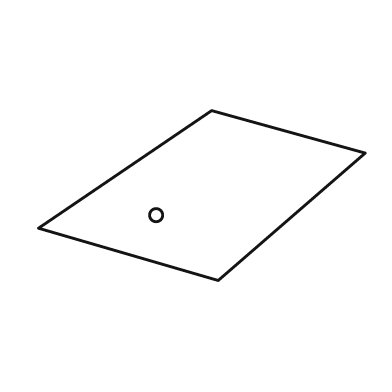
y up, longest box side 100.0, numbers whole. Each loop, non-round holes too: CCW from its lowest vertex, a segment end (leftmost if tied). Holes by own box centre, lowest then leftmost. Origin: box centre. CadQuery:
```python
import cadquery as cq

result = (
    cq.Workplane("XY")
    .moveTo(5.0, -26.0)
    .lineTo(50.0, 13.0)
    .lineTo(3.0, 26.0)
    .lineTo(-50.0, -10.0)
    .close()
    .moveTo(-14.0, -6.0)
    .circle(2.0)
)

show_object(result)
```